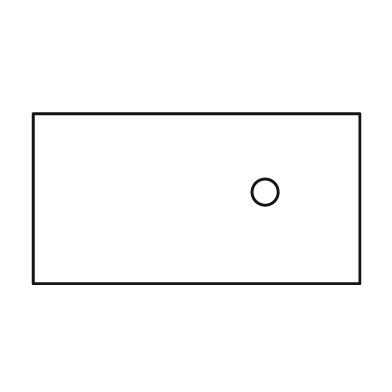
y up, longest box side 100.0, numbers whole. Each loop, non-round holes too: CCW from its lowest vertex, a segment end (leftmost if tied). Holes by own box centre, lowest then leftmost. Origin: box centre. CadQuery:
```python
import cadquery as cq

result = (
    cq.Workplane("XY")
    .moveTo(-50.0, -26.0)
    .lineTo(50.0, -26.0)
    .lineTo(50.0, 26.0)
    .lineTo(-50.0, 26.0)
    .close()
    .moveTo(21.0, 2.0)
    .circle(4.0)
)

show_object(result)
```